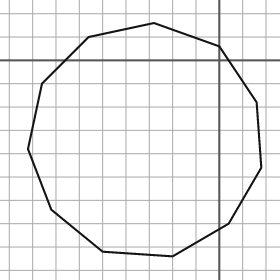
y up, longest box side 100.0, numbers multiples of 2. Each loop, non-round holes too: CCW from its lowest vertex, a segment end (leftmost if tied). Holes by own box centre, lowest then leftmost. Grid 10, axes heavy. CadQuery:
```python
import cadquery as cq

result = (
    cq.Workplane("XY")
    .moveTo(-20.0, -84.0)
    .lineTo(4.0, -70.0)
    .lineTo(18.0, -46.0)
    .lineTo(16.0, -18.0)
    .lineTo(0.0, 6.0)
    .lineTo(-28.0, 16.0)
    .lineTo(-56.0, 10.0)
    .lineTo(-76.0, -10.0)
    .lineTo(-82.0, -38.0)
    .lineTo(-72.0, -64.0)
    .lineTo(-50.0, -82.0)
    .close()
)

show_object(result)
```